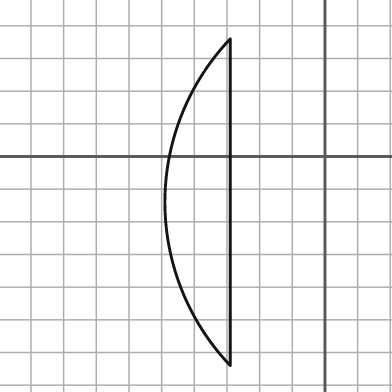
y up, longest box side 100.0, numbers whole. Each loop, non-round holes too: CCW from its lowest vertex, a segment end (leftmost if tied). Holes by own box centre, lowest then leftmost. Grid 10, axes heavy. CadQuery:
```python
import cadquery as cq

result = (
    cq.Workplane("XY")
    .moveTo(-29.0, -64.0)
    .lineTo(-29.0, 36.0)
    .threePointArc((-49.0, -14.0), (-29.0, -64.0))
    .close()
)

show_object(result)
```